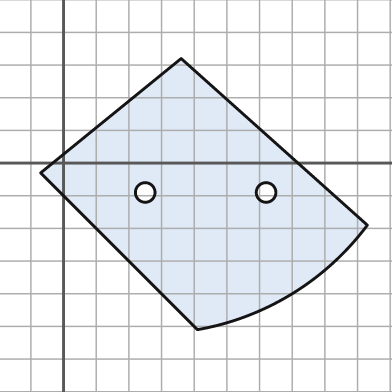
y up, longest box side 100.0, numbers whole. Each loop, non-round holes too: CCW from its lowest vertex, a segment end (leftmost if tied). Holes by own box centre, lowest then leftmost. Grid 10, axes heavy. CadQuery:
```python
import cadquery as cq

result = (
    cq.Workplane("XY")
    .moveTo(41.0, -51.0)
    .threePointArc((70.0, -40.0), (93.0, -19.0))
    .lineTo(36.0, 32.0)
    .lineTo(-7.0, -3.0)
    .close()
    .moveTo(25.0, -9.0)
    .circle(3.0)
    .moveTo(62.0, -9.0)
    .circle(3.0)
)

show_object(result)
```